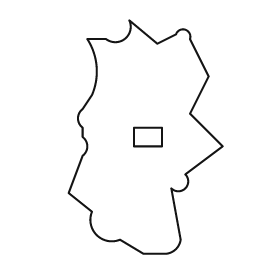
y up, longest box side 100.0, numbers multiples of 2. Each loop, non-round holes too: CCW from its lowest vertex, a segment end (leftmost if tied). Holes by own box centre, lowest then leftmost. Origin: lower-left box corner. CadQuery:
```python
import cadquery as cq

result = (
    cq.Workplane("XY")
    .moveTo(32.0, 0.0)
    .lineTo(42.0, 0.0)
    .threePointArc((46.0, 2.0), (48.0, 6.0))
    .lineTo(44.0, 28.0)
    .threePointArc((50.0, 28.0), (50.0, 34.0))
    .lineTo(66.0, 46.0)
    .lineTo(52.0, 60.0)
    .lineTo(60.0, 76.0)
    .lineTo(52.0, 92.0)
    .threePointArc((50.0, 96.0), (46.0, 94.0))
    .lineTo(38.0, 90.0)
    .lineTo(26.0, 100.0)
    .threePointArc((24.0, 92.0), (16.0, 92.0))
    .lineTo(8.0, 92.0)
    .threePointArc((12.0, 80.0), (10.0, 68.0))
    .lineTo(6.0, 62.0)
    .threePointArc((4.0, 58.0), (6.0, 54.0))
    .lineTo(6.0, 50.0)
    .threePointArc((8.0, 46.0), (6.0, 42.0))
    .lineTo(0.0, 26.0)
    .lineTo(10.0, 18.0)
    .threePointArc((12.0, 8.0), (22.0, 6.0))
    .close()
    .moveTo(28.0, 46.0)
    .lineTo(40.0, 46.0)
    .lineTo(40.0, 54.0)
    .lineTo(28.0, 54.0)
    .close()
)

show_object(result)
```